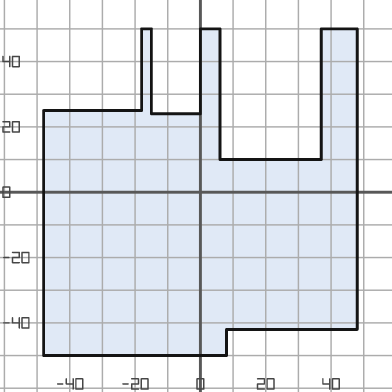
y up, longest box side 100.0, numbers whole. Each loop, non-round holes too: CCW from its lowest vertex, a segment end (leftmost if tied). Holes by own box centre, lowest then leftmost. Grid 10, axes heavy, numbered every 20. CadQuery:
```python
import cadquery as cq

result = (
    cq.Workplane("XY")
    .moveTo(-48.0, -50.0)
    .lineTo(8.0, -50.0)
    .lineTo(8.0, -42.0)
    .lineTo(48.0, -42.0)
    .lineTo(48.0, 50.0)
    .lineTo(37.0, 50.0)
    .lineTo(37.0, 10.0)
    .lineTo(6.0, 10.0)
    .lineTo(6.0, 50.0)
    .lineTo(0.0, 50.0)
    .lineTo(0.0, 24.0)
    .lineTo(-15.0, 24.0)
    .lineTo(-15.0, 50.0)
    .lineTo(-18.0, 50.0)
    .lineTo(-18.0, 25.0)
    .lineTo(-48.0, 25.0)
    .close()
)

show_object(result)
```